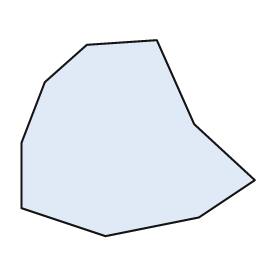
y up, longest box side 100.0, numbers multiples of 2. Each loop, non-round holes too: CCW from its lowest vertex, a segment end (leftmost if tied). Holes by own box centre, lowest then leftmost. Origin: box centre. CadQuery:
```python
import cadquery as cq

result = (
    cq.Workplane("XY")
    .moveTo(-14.0, -42.0)
    .lineTo(26.0, -34.0)
    .lineTo(50.0, -18.0)
    .lineTo(24.0, 6.0)
    .lineTo(8.0, 42.0)
    .lineTo(-22.0, 40.0)
    .lineTo(-40.0, 24.0)
    .lineTo(-50.0, -2.0)
    .lineTo(-50.0, -30.0)
    .close()
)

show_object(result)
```